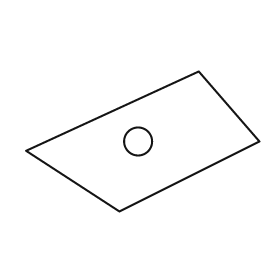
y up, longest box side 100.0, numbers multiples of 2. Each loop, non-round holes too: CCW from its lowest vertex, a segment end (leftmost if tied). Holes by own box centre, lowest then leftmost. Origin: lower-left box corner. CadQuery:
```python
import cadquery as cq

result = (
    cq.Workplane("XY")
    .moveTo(40.0, 0.0)
    .lineTo(100.0, 30.0)
    .lineTo(74.0, 60.0)
    .lineTo(0.0, 26.0)
    .close()
    .moveTo(48.0, 30.0)
    .circle(6.0)
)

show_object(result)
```